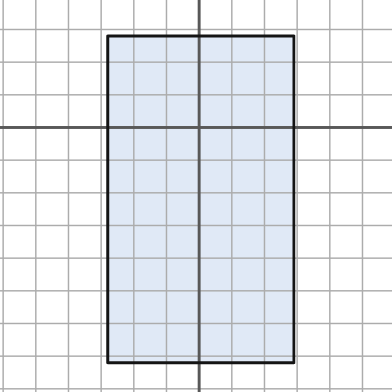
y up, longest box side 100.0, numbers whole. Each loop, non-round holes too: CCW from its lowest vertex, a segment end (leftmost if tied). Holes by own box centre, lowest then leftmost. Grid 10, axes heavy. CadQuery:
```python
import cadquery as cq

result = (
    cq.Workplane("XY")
    .moveTo(-28.0, -72.0)
    .lineTo(29.0, -72.0)
    .lineTo(29.0, 28.0)
    .lineTo(-28.0, 28.0)
    .close()
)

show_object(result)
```